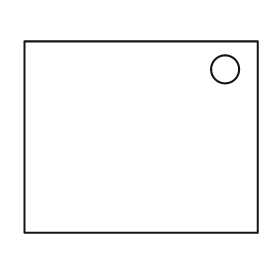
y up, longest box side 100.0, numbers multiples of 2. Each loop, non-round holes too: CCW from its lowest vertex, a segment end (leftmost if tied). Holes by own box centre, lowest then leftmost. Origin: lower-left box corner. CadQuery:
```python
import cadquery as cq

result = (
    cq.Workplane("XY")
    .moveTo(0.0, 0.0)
    .lineTo(100.0, 0.0)
    .lineTo(100.0, 82.0)
    .lineTo(0.0, 82.0)
    .close()
    .moveTo(86.0, 70.0)
    .circle(6.0)
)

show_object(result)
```